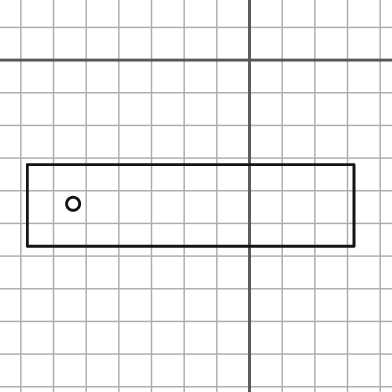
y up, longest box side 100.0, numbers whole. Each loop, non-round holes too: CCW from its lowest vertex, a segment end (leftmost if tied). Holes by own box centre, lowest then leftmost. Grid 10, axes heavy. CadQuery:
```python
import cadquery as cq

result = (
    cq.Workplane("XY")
    .moveTo(-68.0, -57.0)
    .lineTo(32.0, -57.0)
    .lineTo(32.0, -32.0)
    .lineTo(-68.0, -32.0)
    .close()
    .moveTo(-54.0, -44.0)
    .circle(2.0)
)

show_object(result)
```